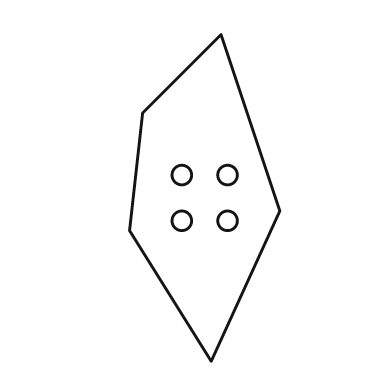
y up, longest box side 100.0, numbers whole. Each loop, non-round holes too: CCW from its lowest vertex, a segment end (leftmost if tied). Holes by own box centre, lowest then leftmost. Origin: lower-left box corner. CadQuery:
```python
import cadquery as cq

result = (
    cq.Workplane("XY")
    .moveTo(25.0, 0.0)
    .lineTo(46.0, 46.0)
    .lineTo(28.0, 100.0)
    .lineTo(4.0, 76.0)
    .lineTo(0.0, 40.0)
    .close()
    .moveTo(16.0, 43.0)
    .circle(3.0)
    .moveTo(30.0, 43.0)
    .circle(3.0)
    .moveTo(16.0, 57.0)
    .circle(3.0)
    .moveTo(30.0, 57.0)
    .circle(3.0)
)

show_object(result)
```